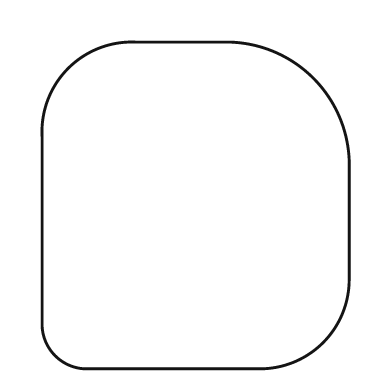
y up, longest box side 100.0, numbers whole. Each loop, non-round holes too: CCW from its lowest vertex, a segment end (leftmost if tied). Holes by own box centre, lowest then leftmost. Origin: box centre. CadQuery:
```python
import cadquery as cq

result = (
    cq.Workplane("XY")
    .moveTo(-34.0, -50.0)
    .lineTo(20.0, -50.0)
    .threePointArc((39.0, -42.0), (47.0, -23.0))
    .lineTo(47.0, 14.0)
    .threePointArc((36.0, 39.0), (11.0, 50.0))
    .lineTo(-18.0, 50.0)
    .threePointArc((-39.0, 42.0), (-47.0, 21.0))
    .lineTo(-47.0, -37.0)
    .threePointArc((-43.0, -46.0), (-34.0, -50.0))
    .close()
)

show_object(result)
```